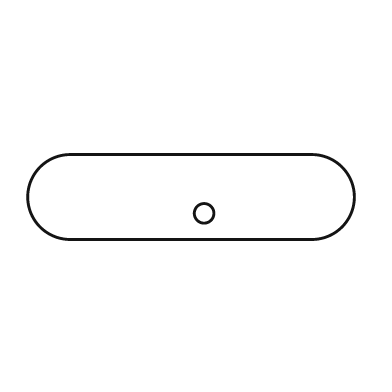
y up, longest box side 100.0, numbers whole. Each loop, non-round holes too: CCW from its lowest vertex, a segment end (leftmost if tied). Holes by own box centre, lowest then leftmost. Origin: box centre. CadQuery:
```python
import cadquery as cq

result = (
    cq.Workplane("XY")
    .moveTo(-37.0, -13.0)
    .lineTo(37.0, -13.0)
    .threePointArc((50.0, 0.0), (37.0, 13.0))
    .lineTo(-37.0, 13.0)
    .threePointArc((-50.0, 0.0), (-37.0, -13.0))
    .close()
    .moveTo(4.0, -5.0)
    .circle(3.0)
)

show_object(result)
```